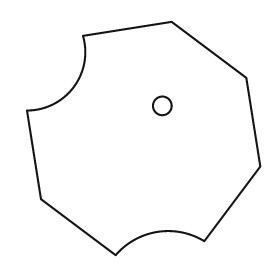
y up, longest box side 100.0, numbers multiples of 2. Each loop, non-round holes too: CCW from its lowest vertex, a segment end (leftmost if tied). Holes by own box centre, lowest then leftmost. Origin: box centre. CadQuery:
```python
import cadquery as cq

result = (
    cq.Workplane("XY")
    .moveTo(-12.0, -50.0)
    .threePointArc((6.0, -40.0), (26.0, -44.0))
    .lineTo(50.0, -12.0)
    .lineTo(44.0, 26.0)
    .lineTo(12.0, 50.0)
    .lineTo(-26.0, 44.0)
    .threePointArc((-30.0, 22.0), (-50.0, 12.0))
    .lineTo(-44.0, -26.0)
    .close()
    .moveTo(8.0, 14.0)
    .circle(4.0)
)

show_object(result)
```